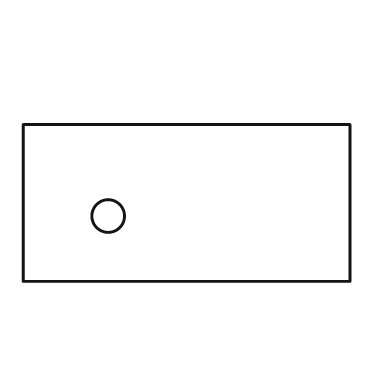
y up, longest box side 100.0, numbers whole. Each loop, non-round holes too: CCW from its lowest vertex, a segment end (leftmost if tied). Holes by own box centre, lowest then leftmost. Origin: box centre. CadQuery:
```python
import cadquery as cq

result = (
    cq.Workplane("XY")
    .moveTo(-50.0, -24.0)
    .lineTo(50.0, -24.0)
    .lineTo(50.0, 24.0)
    .lineTo(-50.0, 24.0)
    .close()
    .moveTo(-24.0, -4.0)
    .circle(5.0)
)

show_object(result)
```